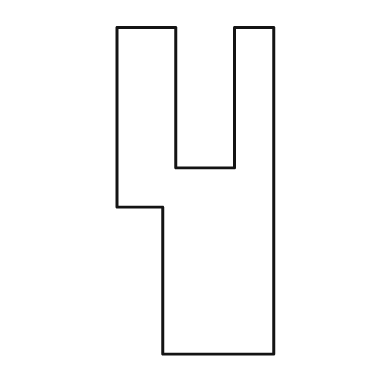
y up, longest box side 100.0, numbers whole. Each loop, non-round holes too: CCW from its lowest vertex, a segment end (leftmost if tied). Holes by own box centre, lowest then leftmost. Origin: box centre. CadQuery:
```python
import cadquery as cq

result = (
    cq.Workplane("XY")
    .moveTo(-10.0, -50.0)
    .lineTo(24.0, -50.0)
    .lineTo(24.0, 50.0)
    .lineTo(12.0, 50.0)
    .lineTo(12.0, 7.0)
    .lineTo(-6.0, 7.0)
    .lineTo(-6.0, 50.0)
    .lineTo(-24.0, 50.0)
    .lineTo(-24.0, -5.0)
    .lineTo(-10.0, -5.0)
    .close()
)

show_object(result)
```